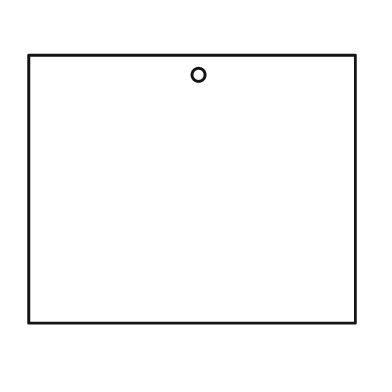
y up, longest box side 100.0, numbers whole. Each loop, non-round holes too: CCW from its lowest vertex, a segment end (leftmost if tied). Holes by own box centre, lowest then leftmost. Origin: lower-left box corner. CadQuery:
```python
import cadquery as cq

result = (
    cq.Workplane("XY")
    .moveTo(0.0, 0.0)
    .lineTo(100.0, 0.0)
    .lineTo(100.0, 82.0)
    .lineTo(0.0, 82.0)
    .close()
    .moveTo(52.0, 76.0)
    .circle(2.0)
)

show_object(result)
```